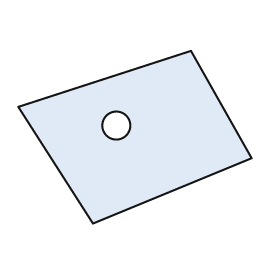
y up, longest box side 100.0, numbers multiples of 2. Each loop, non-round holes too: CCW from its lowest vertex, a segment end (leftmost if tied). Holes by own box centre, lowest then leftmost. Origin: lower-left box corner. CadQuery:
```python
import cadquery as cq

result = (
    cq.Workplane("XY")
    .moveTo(32.0, 0.0)
    .lineTo(100.0, 28.0)
    .lineTo(74.0, 74.0)
    .lineTo(0.0, 50.0)
    .close()
    .moveTo(42.0, 42.0)
    .circle(6.0)
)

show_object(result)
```